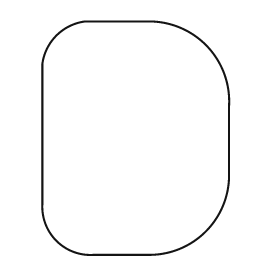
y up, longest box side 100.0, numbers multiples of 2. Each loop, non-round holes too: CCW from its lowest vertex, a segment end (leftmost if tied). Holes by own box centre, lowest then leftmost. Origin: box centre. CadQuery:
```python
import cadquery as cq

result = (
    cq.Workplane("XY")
    .moveTo(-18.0, -50.0)
    .lineTo(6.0, -50.0)
    .threePointArc((30.0, -40.0), (40.0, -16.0))
    .lineTo(40.0, 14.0)
    .threePointArc((30.0, 40.0), (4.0, 50.0))
    .lineTo(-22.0, 50.0)
    .threePointArc((-34.0, 44.0), (-40.0, 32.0))
    .lineTo(-40.0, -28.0)
    .threePointArc((-34.0, -44.0), (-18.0, -50.0))
    .close()
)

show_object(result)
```